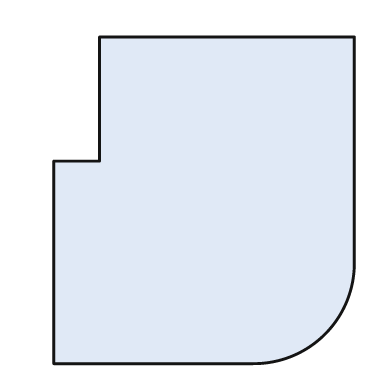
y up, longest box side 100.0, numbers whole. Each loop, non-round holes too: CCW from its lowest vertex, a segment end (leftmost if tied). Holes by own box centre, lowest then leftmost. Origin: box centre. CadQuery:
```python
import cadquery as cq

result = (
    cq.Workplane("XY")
    .moveTo(-46.0, -50.0)
    .lineTo(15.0, -50.0)
    .threePointArc((37.0, -41.0), (46.0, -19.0))
    .lineTo(46.0, 50.0)
    .lineTo(-32.0, 50.0)
    .lineTo(-32.0, 12.0)
    .lineTo(-46.0, 12.0)
    .close()
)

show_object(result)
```